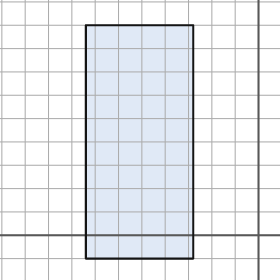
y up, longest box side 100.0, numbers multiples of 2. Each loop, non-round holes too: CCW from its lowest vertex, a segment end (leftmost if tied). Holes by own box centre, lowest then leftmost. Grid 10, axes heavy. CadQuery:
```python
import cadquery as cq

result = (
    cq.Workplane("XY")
    .moveTo(-74.0, -10.0)
    .lineTo(-28.0, -10.0)
    .lineTo(-28.0, 90.0)
    .lineTo(-74.0, 90.0)
    .close()
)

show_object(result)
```